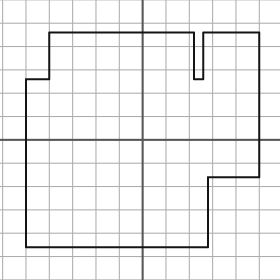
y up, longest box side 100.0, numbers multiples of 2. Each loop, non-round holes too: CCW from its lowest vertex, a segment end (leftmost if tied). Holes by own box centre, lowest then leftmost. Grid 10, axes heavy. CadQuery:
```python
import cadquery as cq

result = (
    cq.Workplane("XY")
    .moveTo(-50.0, -46.0)
    .lineTo(28.0, -46.0)
    .lineTo(28.0, -16.0)
    .lineTo(50.0, -16.0)
    .lineTo(50.0, 46.0)
    .lineTo(26.0, 46.0)
    .lineTo(26.0, 26.0)
    .lineTo(22.0, 26.0)
    .lineTo(22.0, 46.0)
    .lineTo(-40.0, 46.0)
    .lineTo(-40.0, 26.0)
    .lineTo(-50.0, 26.0)
    .close()
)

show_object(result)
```